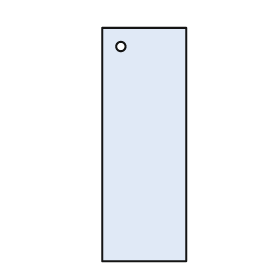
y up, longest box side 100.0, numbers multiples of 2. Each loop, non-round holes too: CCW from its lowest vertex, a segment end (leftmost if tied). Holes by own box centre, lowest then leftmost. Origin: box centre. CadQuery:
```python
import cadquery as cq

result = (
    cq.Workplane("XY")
    .moveTo(-18.0, -50.0)
    .lineTo(18.0, -50.0)
    .lineTo(18.0, 50.0)
    .lineTo(-18.0, 50.0)
    .close()
    .moveTo(-10.0, 42.0)
    .circle(2.0)
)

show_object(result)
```